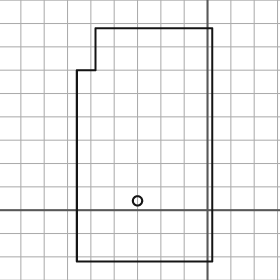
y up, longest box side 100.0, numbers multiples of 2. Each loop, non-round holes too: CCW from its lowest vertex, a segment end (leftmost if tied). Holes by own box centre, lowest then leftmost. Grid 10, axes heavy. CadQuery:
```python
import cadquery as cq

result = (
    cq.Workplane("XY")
    .moveTo(-56.0, -22.0)
    .lineTo(2.0, -22.0)
    .lineTo(2.0, 78.0)
    .lineTo(-48.0, 78.0)
    .lineTo(-48.0, 60.0)
    .lineTo(-56.0, 60.0)
    .close()
    .moveTo(-30.0, 4.0)
    .circle(2.0)
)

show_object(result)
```